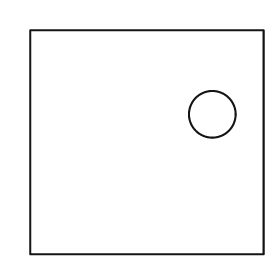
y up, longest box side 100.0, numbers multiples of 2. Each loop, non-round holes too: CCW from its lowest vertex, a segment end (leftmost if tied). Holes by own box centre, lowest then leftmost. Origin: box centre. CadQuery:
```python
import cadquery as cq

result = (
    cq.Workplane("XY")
    .moveTo(-50.0, -48.0)
    .lineTo(50.0, -48.0)
    .lineTo(50.0, 48.0)
    .lineTo(-50.0, 48.0)
    .close()
    .moveTo(28.0, 12.0)
    .circle(10.0)
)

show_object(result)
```